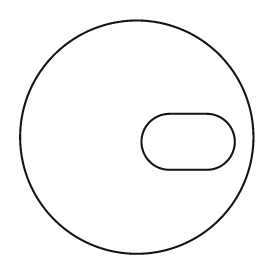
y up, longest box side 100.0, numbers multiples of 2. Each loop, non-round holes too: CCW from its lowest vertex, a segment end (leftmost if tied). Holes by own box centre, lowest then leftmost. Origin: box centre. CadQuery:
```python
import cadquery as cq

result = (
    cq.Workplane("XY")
    .moveTo(0.0, 0.0)
    .circle(50.0)
    .moveTo(14.0, -14.0)
    .lineTo(30.0, -14.0)
    .threePointArc((42.0, -2.0), (30.0, 10.0))
    .lineTo(14.0, 10.0)
    .threePointArc((2.0, -2.0), (14.0, -14.0))
    .close()
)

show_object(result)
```